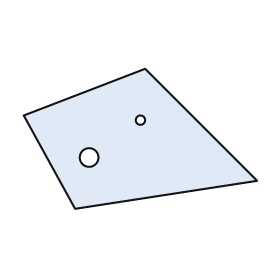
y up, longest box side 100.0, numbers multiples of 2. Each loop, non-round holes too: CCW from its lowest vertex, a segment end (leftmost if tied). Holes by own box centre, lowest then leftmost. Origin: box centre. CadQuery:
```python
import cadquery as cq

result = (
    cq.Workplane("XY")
    .moveTo(-28.0, -30.0)
    .lineTo(50.0, -18.0)
    .lineTo(2.0, 30.0)
    .lineTo(-50.0, 10.0)
    .close()
    .moveTo(-22.0, -8.0)
    .circle(4.0)
    .moveTo(0.0, 8.0)
    .circle(2.0)
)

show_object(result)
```